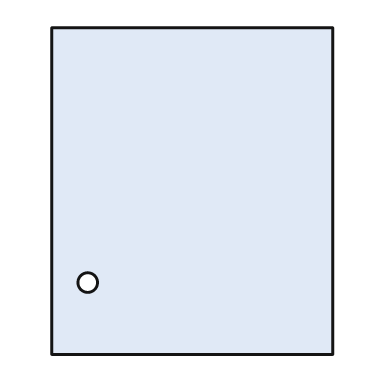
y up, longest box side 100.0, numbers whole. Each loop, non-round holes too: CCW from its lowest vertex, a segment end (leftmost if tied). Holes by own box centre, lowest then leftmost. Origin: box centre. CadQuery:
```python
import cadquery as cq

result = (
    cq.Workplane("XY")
    .moveTo(-43.0, -50.0)
    .lineTo(43.0, -50.0)
    .lineTo(43.0, 50.0)
    .lineTo(-43.0, 50.0)
    .close()
    .moveTo(-32.0, -28.0)
    .circle(3.0)
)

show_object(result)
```